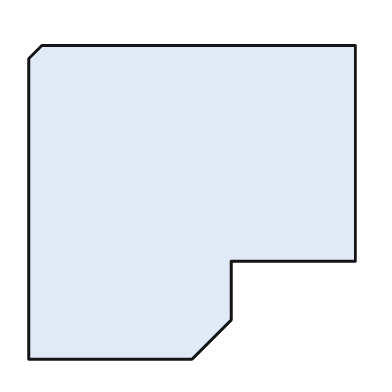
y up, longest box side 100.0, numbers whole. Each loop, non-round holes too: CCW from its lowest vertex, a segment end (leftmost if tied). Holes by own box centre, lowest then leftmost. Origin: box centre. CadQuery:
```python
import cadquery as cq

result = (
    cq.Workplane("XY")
    .moveTo(-50.0, -48.0)
    .lineTo(0.0, -48.0)
    .lineTo(12.0, -36.0)
    .lineTo(12.0, -18.0)
    .lineTo(50.0, -18.0)
    .lineTo(50.0, 48.0)
    .lineTo(-46.0, 48.0)
    .lineTo(-50.0, 44.0)
    .close()
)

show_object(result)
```